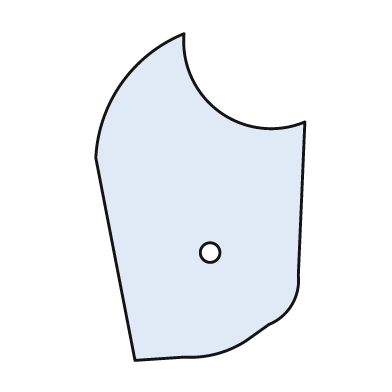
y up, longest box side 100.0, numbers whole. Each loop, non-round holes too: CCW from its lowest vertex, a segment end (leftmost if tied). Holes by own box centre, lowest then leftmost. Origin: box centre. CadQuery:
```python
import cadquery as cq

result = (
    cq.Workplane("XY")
    .moveTo(-20.0, -50.0)
    .lineTo(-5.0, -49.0)
    .threePointArc((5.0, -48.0), (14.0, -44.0))
    .lineTo(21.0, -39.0)
    .threePointArc((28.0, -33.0), (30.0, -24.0))
    .lineTo(32.0, 23.0)
    .threePointArc((6.0, 26.0), (-5.0, 50.0))
    .threePointArc((-24.0, 35.0), (-32.0, 12.0))
    .close()
    .moveTo(3.0, -17.0)
    .circle(3.0)
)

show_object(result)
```